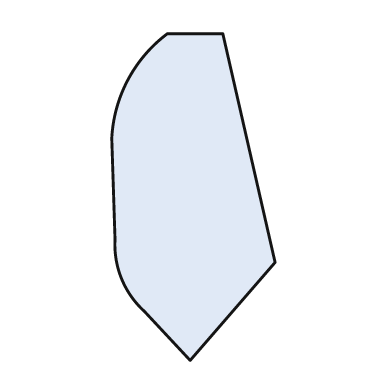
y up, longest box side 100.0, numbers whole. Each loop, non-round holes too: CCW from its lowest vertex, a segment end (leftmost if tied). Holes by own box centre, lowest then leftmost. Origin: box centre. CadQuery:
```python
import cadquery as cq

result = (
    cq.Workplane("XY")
    .moveTo(-1.0, -50.0)
    .lineTo(25.0, -20.0)
    .lineTo(9.0, 50.0)
    .lineTo(-8.0, 50.0)
    .threePointArc((-20.0, 36.0), (-25.0, 18.0))
    .lineTo(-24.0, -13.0)
    .threePointArc((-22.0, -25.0), (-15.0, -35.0))
    .close()
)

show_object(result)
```